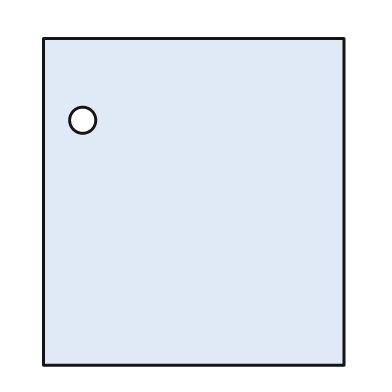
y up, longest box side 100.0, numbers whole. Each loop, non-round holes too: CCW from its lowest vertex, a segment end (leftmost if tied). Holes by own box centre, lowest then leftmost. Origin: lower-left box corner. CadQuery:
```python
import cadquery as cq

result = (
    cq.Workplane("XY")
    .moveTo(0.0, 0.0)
    .lineTo(92.0, 0.0)
    .lineTo(92.0, 100.0)
    .lineTo(0.0, 100.0)
    .close()
    .moveTo(12.0, 75.0)
    .circle(4.0)
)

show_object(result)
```